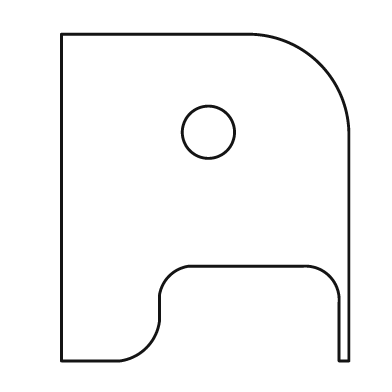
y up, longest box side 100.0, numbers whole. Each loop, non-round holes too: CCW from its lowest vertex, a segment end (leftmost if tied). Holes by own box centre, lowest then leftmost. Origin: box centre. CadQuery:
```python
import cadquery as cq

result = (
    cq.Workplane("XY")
    .moveTo(-44.0, -50.0)
    .lineTo(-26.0, -50.0)
    .threePointArc((-18.0, -46.0), (-14.0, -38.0))
    .lineTo(-14.0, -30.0)
    .threePointArc((-11.0, -24.0), (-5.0, -21.0))
    .lineTo(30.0, -21.0)
    .threePointArc((38.0, -24.0), (41.0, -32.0))
    .lineTo(41.0, -50.0)
    .lineTo(44.0, -50.0)
    .lineTo(44.0, 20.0)
    .threePointArc((35.0, 41.0), (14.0, 50.0))
    .lineTo(-44.0, 50.0)
    .close()
    .moveTo(1.0, 20.0)
    .circle(8.0)
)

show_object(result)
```